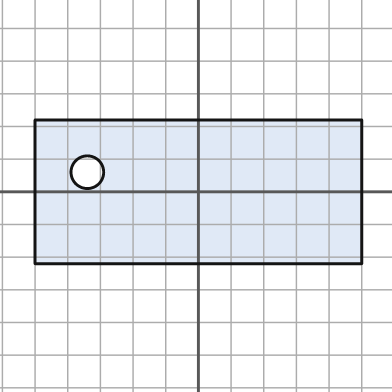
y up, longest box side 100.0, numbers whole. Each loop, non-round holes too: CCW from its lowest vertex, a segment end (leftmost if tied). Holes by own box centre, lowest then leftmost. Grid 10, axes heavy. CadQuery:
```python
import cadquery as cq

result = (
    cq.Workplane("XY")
    .moveTo(-50.0, -22.0)
    .lineTo(50.0, -22.0)
    .lineTo(50.0, 22.0)
    .lineTo(-50.0, 22.0)
    .close()
    .moveTo(-34.0, 6.0)
    .circle(5.0)
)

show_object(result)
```